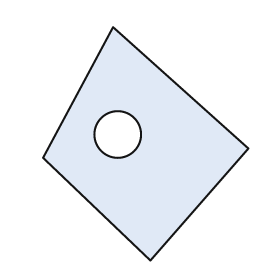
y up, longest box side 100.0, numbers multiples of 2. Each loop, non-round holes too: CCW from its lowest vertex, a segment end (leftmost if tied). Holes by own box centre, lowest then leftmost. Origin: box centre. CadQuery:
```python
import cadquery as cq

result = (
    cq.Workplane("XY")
    .moveTo(2.0, -50.0)
    .lineTo(44.0, -2.0)
    .lineTo(-14.0, 50.0)
    .lineTo(-44.0, -6.0)
    .close()
    .moveTo(-12.0, 4.0)
    .circle(10.0)
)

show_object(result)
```